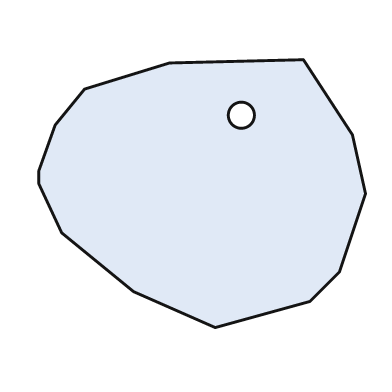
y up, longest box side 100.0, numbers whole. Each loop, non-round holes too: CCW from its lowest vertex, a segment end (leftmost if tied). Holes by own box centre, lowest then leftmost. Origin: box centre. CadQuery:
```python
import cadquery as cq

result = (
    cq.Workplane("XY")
    .moveTo(4.0, -41.0)
    .lineTo(33.0, -33.0)
    .lineTo(42.0, -24.0)
    .lineTo(50.0, 0.0)
    .lineTo(46.0, 18.0)
    .lineTo(31.0, 41.0)
    .lineTo(-10.0, 40.0)
    .lineTo(-36.0, 32.0)
    .lineTo(-45.0, 21.0)
    .lineTo(-50.0, 7.0)
    .lineTo(-50.0, 3.0)
    .lineTo(-43.0, -12.0)
    .lineTo(-21.0, -30.0)
    .close()
    .moveTo(12.0, 24.0)
    .circle(4.0)
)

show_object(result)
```